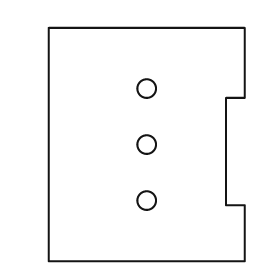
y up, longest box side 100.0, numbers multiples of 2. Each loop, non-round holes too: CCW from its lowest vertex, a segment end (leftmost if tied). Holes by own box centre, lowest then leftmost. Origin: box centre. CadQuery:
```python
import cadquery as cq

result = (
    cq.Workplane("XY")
    .moveTo(-42.0, -50.0)
    .lineTo(42.0, -50.0)
    .lineTo(42.0, -26.0)
    .lineTo(34.0, -26.0)
    .lineTo(34.0, 20.0)
    .lineTo(42.0, 20.0)
    .lineTo(42.0, 50.0)
    .lineTo(-42.0, 50.0)
    .close()
    .moveTo(0.0, -24.0)
    .circle(4.0)
    .moveTo(0.0, 0.0)
    .circle(4.0)
    .moveTo(0.0, 24.0)
    .circle(4.0)
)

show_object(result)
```